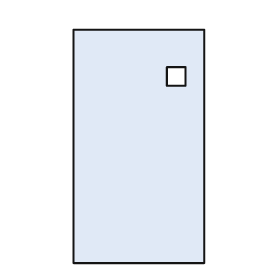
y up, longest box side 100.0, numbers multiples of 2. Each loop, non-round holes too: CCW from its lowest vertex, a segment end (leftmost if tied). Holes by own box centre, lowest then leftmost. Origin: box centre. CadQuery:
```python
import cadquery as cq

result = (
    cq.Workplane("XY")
    .moveTo(-28.0, -50.0)
    .lineTo(28.0, -50.0)
    .lineTo(28.0, 50.0)
    .lineTo(-28.0, 50.0)
    .close()
    .moveTo(12.0, 26.0)
    .lineTo(20.0, 26.0)
    .lineTo(20.0, 34.0)
    .lineTo(12.0, 34.0)
    .close()
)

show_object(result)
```